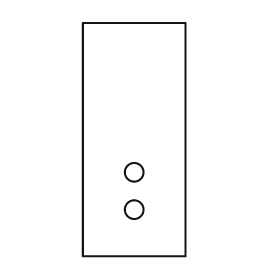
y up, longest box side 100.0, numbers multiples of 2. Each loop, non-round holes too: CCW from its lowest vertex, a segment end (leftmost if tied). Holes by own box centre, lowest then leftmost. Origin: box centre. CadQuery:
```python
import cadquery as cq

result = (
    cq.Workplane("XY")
    .moveTo(-22.0, -50.0)
    .lineTo(22.0, -50.0)
    .lineTo(22.0, 50.0)
    .lineTo(-22.0, 50.0)
    .close()
    .moveTo(0.0, -30.0)
    .circle(4.0)
    .moveTo(0.0, -14.0)
    .circle(4.0)
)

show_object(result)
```